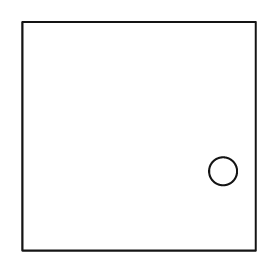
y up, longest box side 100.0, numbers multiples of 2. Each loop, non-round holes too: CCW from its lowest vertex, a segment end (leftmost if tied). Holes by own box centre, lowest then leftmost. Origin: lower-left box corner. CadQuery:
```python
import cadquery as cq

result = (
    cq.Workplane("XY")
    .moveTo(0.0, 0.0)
    .lineTo(100.0, 0.0)
    .lineTo(100.0, 98.0)
    .lineTo(0.0, 98.0)
    .close()
    .moveTo(86.0, 34.0)
    .circle(6.0)
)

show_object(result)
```